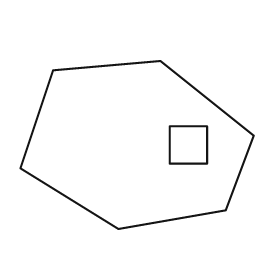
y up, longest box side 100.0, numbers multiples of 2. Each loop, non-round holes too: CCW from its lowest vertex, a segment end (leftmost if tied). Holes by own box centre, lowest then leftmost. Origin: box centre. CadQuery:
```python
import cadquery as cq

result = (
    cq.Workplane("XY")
    .moveTo(-8.0, -36.0)
    .lineTo(38.0, -28.0)
    .lineTo(50.0, 4.0)
    .lineTo(10.0, 36.0)
    .lineTo(-36.0, 32.0)
    .lineTo(-50.0, -10.0)
    .close()
    .moveTo(14.0, -8.0)
    .lineTo(30.0, -8.0)
    .lineTo(30.0, 8.0)
    .lineTo(14.0, 8.0)
    .close()
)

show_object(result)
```